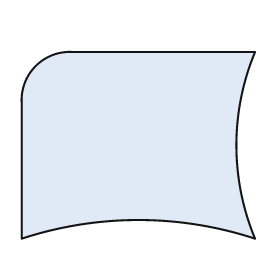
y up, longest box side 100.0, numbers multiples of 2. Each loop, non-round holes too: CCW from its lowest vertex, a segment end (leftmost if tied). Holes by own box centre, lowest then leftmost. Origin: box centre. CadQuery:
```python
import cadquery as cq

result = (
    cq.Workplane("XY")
    .moveTo(-50.0, -40.0)
    .threePointArc((0.0, -32.0), (50.0, -40.0))
    .threePointArc((42.0, 0.0), (50.0, 40.0))
    .lineTo(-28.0, 40.0)
    .threePointArc((-44.0, 34.0), (-50.0, 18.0))
    .close()
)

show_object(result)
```